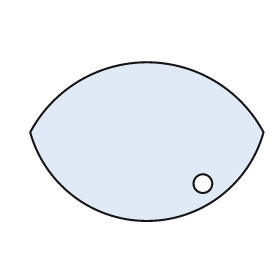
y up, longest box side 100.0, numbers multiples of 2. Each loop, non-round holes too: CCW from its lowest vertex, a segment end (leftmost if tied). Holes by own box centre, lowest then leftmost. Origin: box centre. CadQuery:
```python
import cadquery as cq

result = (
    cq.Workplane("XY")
    .moveTo(-50.0, 4.0)
    .threePointArc((0.0, -34.0), (50.0, 4.0))
    .threePointArc((0.0, 34.0), (-50.0, 4.0))
    .close()
    .moveTo(24.0, -18.0)
    .circle(4.0)
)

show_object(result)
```